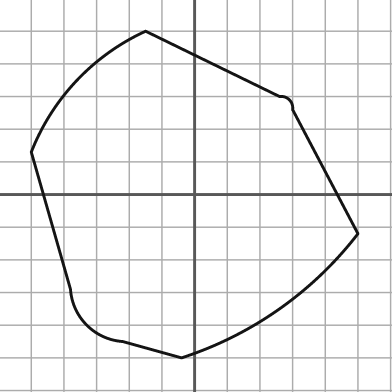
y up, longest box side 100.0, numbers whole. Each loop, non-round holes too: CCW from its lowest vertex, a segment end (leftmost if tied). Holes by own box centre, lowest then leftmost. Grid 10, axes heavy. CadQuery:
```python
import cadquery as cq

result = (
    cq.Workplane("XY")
    .moveTo(-4.0, -50.0)
    .threePointArc((26.0, -35.0), (50.0, -12.0))
    .lineTo(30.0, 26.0)
    .threePointArc((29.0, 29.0), (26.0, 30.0))
    .lineTo(-15.0, 50.0)
    .threePointArc((-36.0, 35.0), (-50.0, 13.0))
    .lineTo(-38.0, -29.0)
    .threePointArc((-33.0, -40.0), (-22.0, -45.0))
    .close()
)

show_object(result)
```